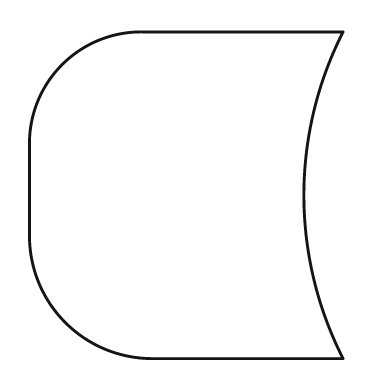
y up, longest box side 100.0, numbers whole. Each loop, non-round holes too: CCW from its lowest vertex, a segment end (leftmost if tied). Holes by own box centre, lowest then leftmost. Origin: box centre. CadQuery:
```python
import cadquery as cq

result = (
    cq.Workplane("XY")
    .moveTo(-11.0, -50.0)
    .lineTo(48.0, -50.0)
    .threePointArc((36.0, 0.0), (48.0, 50.0))
    .lineTo(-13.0, 50.0)
    .threePointArc((-38.0, 40.0), (-48.0, 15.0))
    .lineTo(-48.0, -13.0)
    .threePointArc((-37.0, -39.0), (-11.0, -50.0))
    .close()
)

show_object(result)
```